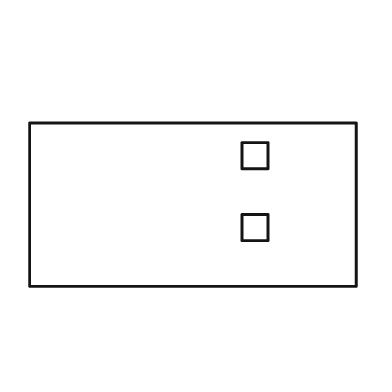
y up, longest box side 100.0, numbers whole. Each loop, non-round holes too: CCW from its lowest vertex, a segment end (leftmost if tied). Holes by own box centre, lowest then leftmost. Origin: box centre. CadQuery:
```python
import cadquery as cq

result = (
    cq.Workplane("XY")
    .moveTo(-50.0, -25.0)
    .lineTo(50.0, -25.0)
    .lineTo(50.0, 25.0)
    .lineTo(-50.0, 25.0)
    .close()
    .moveTo(15.0, -11.0)
    .lineTo(23.0, -11.0)
    .lineTo(23.0, -3.0)
    .lineTo(15.0, -3.0)
    .close()
    .moveTo(15.0, 11.0)
    .lineTo(23.0, 11.0)
    .lineTo(23.0, 19.0)
    .lineTo(15.0, 19.0)
    .close()
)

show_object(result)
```